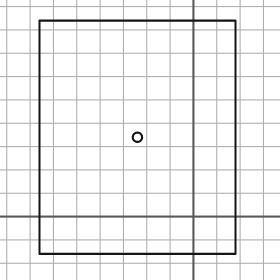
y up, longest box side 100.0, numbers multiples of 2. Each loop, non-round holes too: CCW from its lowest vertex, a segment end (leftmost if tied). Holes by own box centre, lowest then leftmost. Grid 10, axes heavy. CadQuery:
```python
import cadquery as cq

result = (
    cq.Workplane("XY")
    .moveTo(-66.0, -16.0)
    .lineTo(18.0, -16.0)
    .lineTo(18.0, 84.0)
    .lineTo(-66.0, 84.0)
    .close()
    .moveTo(-24.0, 34.0)
    .circle(2.0)
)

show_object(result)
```